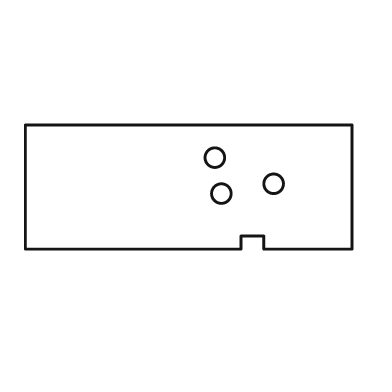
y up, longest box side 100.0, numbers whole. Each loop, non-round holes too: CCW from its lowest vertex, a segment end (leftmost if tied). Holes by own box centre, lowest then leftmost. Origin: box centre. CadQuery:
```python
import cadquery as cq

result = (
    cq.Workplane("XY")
    .moveTo(-50.0, -19.0)
    .lineTo(16.0, -19.0)
    .lineTo(16.0, -15.0)
    .lineTo(23.0, -15.0)
    .lineTo(23.0, -19.0)
    .lineTo(50.0, -19.0)
    .lineTo(50.0, 19.0)
    .lineTo(-50.0, 19.0)
    .close()
    .moveTo(10.0, -2.0)
    .circle(3.0)
    .moveTo(26.0, 1.0)
    .circle(3.0)
    .moveTo(8.0, 9.0)
    .circle(3.0)
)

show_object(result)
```